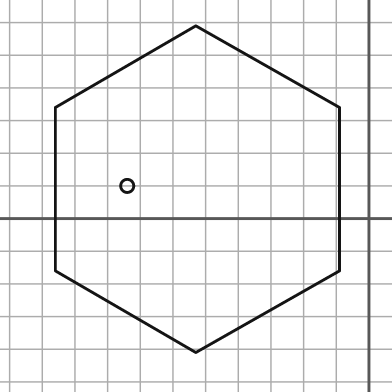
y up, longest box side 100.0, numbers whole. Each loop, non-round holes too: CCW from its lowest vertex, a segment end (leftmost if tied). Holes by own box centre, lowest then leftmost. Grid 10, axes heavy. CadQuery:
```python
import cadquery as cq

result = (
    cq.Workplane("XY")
    .moveTo(-53.0, -41.0)
    .lineTo(-9.0, -16.0)
    .lineTo(-9.0, 34.0)
    .lineTo(-53.0, 59.0)
    .lineTo(-96.0, 34.0)
    .lineTo(-96.0, -16.0)
    .close()
    .moveTo(-74.0, 10.0)
    .circle(2.0)
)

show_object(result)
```